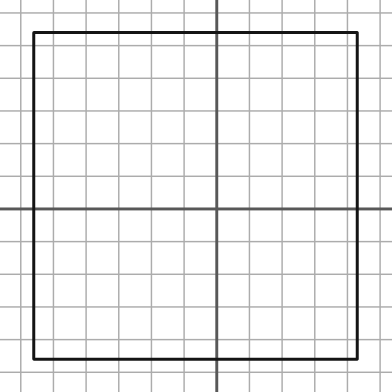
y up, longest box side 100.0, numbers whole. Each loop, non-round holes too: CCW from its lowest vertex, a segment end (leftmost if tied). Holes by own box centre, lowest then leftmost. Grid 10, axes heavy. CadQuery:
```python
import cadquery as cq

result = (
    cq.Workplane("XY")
    .moveTo(-56.0, -46.0)
    .lineTo(43.0, -46.0)
    .lineTo(43.0, 54.0)
    .lineTo(-56.0, 54.0)
    .close()
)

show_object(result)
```